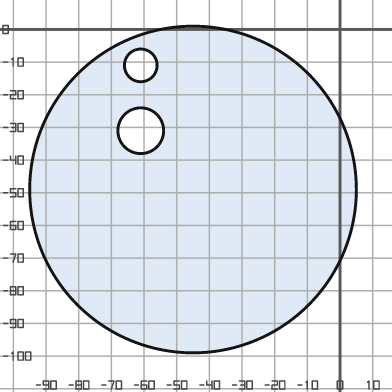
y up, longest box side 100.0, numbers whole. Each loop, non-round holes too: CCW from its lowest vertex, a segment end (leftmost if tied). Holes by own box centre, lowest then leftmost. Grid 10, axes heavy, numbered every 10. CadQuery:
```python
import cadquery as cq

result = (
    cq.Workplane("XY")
    .moveTo(-45.0, -49.0)
    .circle(50.0)
    .moveTo(-61.0, -31.0)
    .circle(7.0)
    .moveTo(-61.0, -11.0)
    .circle(5.0)
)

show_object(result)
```